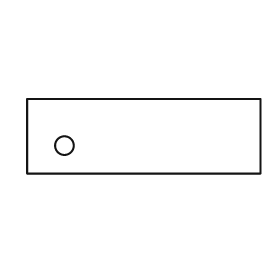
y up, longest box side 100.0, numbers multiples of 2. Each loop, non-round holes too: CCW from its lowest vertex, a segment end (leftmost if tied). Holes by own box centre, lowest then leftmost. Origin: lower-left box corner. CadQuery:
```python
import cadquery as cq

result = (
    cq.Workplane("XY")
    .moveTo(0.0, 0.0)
    .lineTo(100.0, 0.0)
    .lineTo(100.0, 32.0)
    .lineTo(0.0, 32.0)
    .close()
    .moveTo(16.0, 12.0)
    .circle(4.0)
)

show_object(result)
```